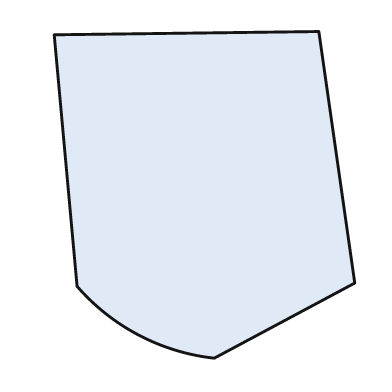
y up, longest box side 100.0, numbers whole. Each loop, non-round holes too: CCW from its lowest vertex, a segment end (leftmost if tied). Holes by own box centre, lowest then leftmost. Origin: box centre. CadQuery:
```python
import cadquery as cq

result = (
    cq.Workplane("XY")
    .moveTo(3.0, -50.0)
    .lineTo(46.0, -27.0)
    .lineTo(35.0, 50.0)
    .lineTo(-46.0, 49.0)
    .lineTo(-39.0, -28.0)
    .threePointArc((-20.0, -43.0), (3.0, -50.0))
    .close()
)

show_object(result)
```